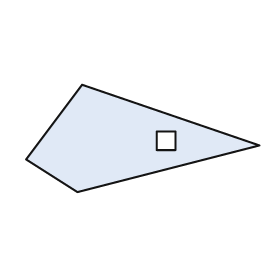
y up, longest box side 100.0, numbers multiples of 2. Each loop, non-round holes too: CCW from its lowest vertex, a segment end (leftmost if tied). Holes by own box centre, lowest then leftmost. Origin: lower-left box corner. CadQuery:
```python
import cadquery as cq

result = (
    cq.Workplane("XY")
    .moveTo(22.0, 0.0)
    .lineTo(100.0, 20.0)
    .lineTo(24.0, 46.0)
    .lineTo(0.0, 14.0)
    .close()
    .moveTo(56.0, 18.0)
    .lineTo(64.0, 18.0)
    .lineTo(64.0, 26.0)
    .lineTo(56.0, 26.0)
    .close()
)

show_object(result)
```